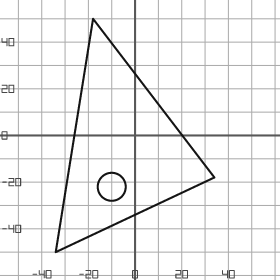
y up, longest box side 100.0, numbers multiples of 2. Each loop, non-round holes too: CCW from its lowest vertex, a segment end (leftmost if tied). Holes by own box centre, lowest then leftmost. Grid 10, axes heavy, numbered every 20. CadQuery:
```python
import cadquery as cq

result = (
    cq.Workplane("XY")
    .moveTo(-34.0, -50.0)
    .lineTo(34.0, -18.0)
    .lineTo(-18.0, 50.0)
    .close()
    .moveTo(-10.0, -22.0)
    .circle(6.0)
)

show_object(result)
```